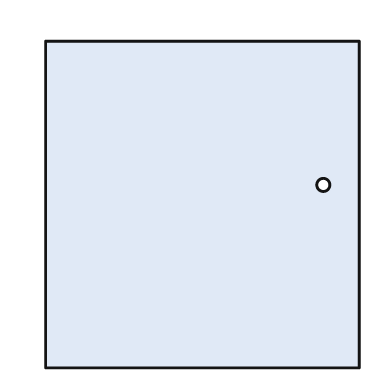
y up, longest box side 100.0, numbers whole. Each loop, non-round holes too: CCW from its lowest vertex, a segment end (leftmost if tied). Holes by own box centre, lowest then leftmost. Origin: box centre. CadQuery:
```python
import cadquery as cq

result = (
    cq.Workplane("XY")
    .moveTo(-48.0, -50.0)
    .lineTo(48.0, -50.0)
    .lineTo(48.0, 50.0)
    .lineTo(-48.0, 50.0)
    .close()
    .moveTo(37.0, 6.0)
    .circle(2.0)
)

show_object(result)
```